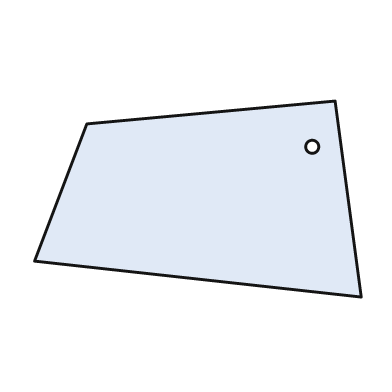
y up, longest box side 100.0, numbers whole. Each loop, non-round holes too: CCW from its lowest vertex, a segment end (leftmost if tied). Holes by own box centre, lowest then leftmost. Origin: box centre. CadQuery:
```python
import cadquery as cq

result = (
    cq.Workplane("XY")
    .moveTo(50.0, -30.0)
    .lineTo(42.0, 30.0)
    .lineTo(-34.0, 23.0)
    .lineTo(-50.0, -19.0)
    .close()
    .moveTo(35.0, 16.0)
    .circle(2.0)
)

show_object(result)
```